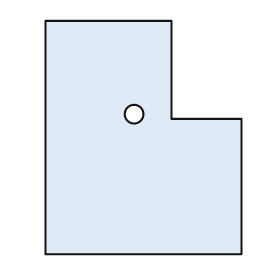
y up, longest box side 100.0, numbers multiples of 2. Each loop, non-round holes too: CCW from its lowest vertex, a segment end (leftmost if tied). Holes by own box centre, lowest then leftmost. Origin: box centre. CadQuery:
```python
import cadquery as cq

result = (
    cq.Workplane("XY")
    .moveTo(-42.0, -50.0)
    .lineTo(42.0, -50.0)
    .lineTo(42.0, 8.0)
    .lineTo(12.0, 8.0)
    .lineTo(12.0, 50.0)
    .lineTo(-42.0, 50.0)
    .close()
    .moveTo(-4.0, 10.0)
    .circle(4.0)
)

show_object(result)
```